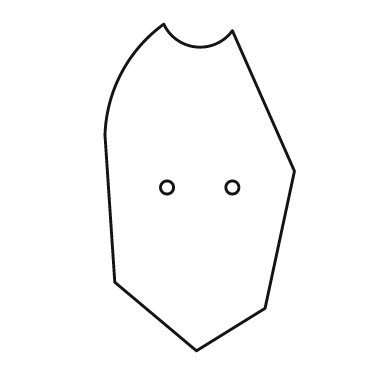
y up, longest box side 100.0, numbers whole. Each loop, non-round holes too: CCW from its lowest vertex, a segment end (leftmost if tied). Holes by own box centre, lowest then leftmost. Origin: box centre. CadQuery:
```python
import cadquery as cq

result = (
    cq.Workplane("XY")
    .moveTo(-1.0, -50.0)
    .lineTo(20.0, -37.0)
    .lineTo(29.0, 5.0)
    .lineTo(10.0, 48.0)
    .threePointArc((-1.0, 43.0), (-11.0, 50.0))
    .threePointArc((-24.0, 35.0), (-29.0, 16.0))
    .lineTo(-26.0, -29.0)
    .close()
    .moveTo(-10.0, 0.0)
    .circle(2.0)
    .moveTo(10.0, 0.0)
    .circle(2.0)
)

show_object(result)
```